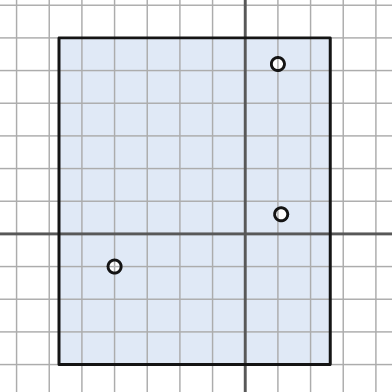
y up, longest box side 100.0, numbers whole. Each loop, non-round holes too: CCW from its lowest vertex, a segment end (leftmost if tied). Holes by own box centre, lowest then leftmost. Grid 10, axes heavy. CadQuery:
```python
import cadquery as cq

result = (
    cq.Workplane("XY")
    .moveTo(-57.0, -40.0)
    .lineTo(26.0, -40.0)
    .lineTo(26.0, 60.0)
    .lineTo(-57.0, 60.0)
    .close()
    .moveTo(-40.0, -10.0)
    .circle(2.0)
    .moveTo(11.0, 6.0)
    .circle(2.0)
    .moveTo(10.0, 52.0)
    .circle(2.0)
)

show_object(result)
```